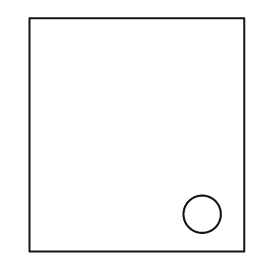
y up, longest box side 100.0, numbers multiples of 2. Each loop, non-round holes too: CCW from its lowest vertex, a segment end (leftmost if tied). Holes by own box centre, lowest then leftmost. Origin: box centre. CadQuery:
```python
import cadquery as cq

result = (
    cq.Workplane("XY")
    .moveTo(-46.0, -50.0)
    .lineTo(46.0, -50.0)
    .lineTo(46.0, 50.0)
    .lineTo(-46.0, 50.0)
    .close()
    .moveTo(28.0, -34.0)
    .circle(8.0)
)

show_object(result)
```